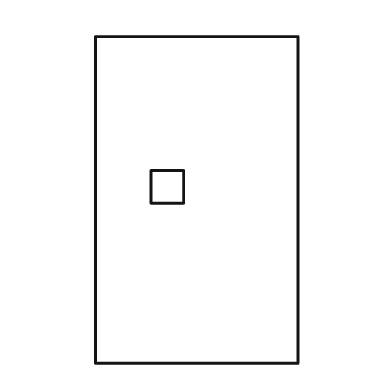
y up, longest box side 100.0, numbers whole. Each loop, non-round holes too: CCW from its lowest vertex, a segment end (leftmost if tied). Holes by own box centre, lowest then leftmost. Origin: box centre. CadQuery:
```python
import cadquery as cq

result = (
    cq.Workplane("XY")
    .moveTo(-31.0, -50.0)
    .lineTo(31.0, -50.0)
    .lineTo(31.0, 50.0)
    .lineTo(-31.0, 50.0)
    .close()
    .moveTo(-14.0, -1.0)
    .lineTo(-4.0, -1.0)
    .lineTo(-4.0, 9.0)
    .lineTo(-14.0, 9.0)
    .close()
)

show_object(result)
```